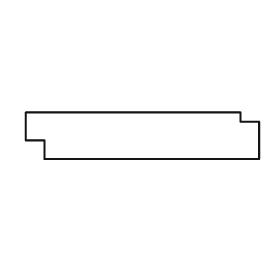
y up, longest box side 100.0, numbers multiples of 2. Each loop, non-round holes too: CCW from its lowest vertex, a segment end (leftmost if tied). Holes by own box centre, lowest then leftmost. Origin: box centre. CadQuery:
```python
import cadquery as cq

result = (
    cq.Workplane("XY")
    .moveTo(-42.0, -10.0)
    .lineTo(50.0, -10.0)
    .lineTo(50.0, 6.0)
    .lineTo(42.0, 6.0)
    .lineTo(42.0, 10.0)
    .lineTo(-50.0, 10.0)
    .lineTo(-50.0, -2.0)
    .lineTo(-42.0, -2.0)
    .close()
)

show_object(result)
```